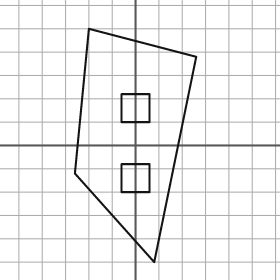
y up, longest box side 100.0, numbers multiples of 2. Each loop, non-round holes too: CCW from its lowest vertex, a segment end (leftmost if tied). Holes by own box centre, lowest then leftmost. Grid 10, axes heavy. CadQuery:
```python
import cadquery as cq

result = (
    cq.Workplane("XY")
    .moveTo(8.0, -50.0)
    .lineTo(26.0, 38.0)
    .lineTo(-20.0, 50.0)
    .lineTo(-26.0, -12.0)
    .close()
    .moveTo(-6.0, -20.0)
    .lineTo(6.0, -20.0)
    .lineTo(6.0, -8.0)
    .lineTo(-6.0, -8.0)
    .close()
    .moveTo(-6.0, 10.0)
    .lineTo(6.0, 10.0)
    .lineTo(6.0, 22.0)
    .lineTo(-6.0, 22.0)
    .close()
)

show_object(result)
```